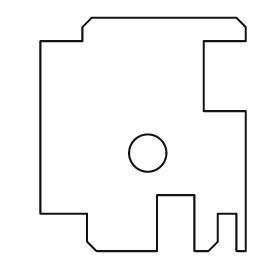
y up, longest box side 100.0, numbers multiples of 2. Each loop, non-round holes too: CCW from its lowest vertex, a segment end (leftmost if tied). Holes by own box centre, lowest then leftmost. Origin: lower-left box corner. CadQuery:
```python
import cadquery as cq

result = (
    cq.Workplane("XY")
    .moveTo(24.0, 0.0)
    .lineTo(50.0, 0.0)
    .lineTo(50.0, 24.0)
    .lineTo(66.0, 24.0)
    .lineTo(66.0, 0.0)
    .lineTo(72.0, 0.0)
    .lineTo(76.0, 4.0)
    .lineTo(76.0, 16.0)
    .lineTo(84.0, 16.0)
    .lineTo(84.0, 0.0)
    .lineTo(88.0, 0.0)
    .lineTo(88.0, 60.0)
    .lineTo(70.0, 60.0)
    .lineTo(70.0, 90.0)
    .lineTo(88.0, 90.0)
    .lineTo(88.0, 96.0)
    .lineTo(84.0, 100.0)
    .lineTo(22.0, 100.0)
    .lineTo(18.0, 96.0)
    .lineTo(18.0, 90.0)
    .lineTo(0.0, 90.0)
    .lineTo(0.0, 16.0)
    .lineTo(20.0, 16.0)
    .lineTo(20.0, 4.0)
    .close()
    .moveTo(46.0, 42.0)
    .circle(8.0)
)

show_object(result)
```